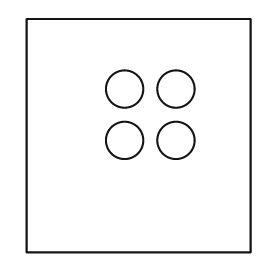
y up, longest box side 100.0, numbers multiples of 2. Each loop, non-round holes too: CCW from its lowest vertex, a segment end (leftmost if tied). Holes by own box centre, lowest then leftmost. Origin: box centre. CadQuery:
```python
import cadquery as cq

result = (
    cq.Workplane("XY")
    .moveTo(-48.0, -50.0)
    .lineTo(48.0, -50.0)
    .lineTo(48.0, 50.0)
    .lineTo(-48.0, 50.0)
    .close()
    .moveTo(-6.0, -2.0)
    .circle(8.0)
    .moveTo(16.0, -2.0)
    .circle(8.0)
    .moveTo(-6.0, 20.0)
    .circle(8.0)
    .moveTo(16.0, 20.0)
    .circle(8.0)
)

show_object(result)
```